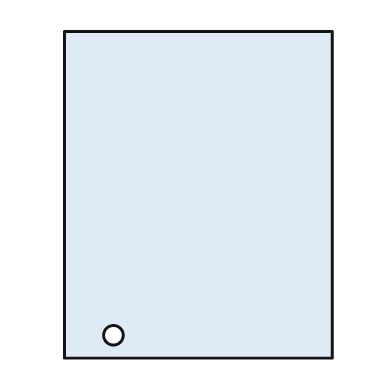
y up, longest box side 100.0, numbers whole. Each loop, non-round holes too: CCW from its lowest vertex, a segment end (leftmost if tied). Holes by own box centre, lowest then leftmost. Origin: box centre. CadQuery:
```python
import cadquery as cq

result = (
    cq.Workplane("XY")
    .moveTo(-41.0, -50.0)
    .lineTo(41.0, -50.0)
    .lineTo(41.0, 50.0)
    .lineTo(-41.0, 50.0)
    .close()
    .moveTo(-26.0, -43.0)
    .circle(3.0)
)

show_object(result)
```